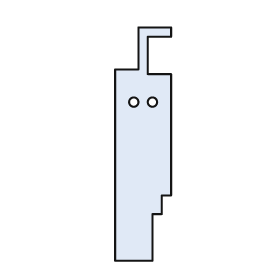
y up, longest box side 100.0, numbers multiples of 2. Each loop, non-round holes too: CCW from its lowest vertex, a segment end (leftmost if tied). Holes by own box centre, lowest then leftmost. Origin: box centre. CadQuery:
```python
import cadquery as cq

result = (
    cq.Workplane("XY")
    .moveTo(-12.0, -50.0)
    .lineTo(4.0, -50.0)
    .lineTo(4.0, -30.0)
    .lineTo(8.0, -30.0)
    .lineTo(8.0, -22.0)
    .lineTo(12.0, -22.0)
    .lineTo(12.0, 30.0)
    .lineTo(2.0, 30.0)
    .lineTo(2.0, 46.0)
    .lineTo(12.0, 46.0)
    .lineTo(12.0, 50.0)
    .lineTo(-2.0, 50.0)
    .lineTo(-2.0, 32.0)
    .lineTo(-12.0, 32.0)
    .close()
    .moveTo(-4.0, 18.0)
    .circle(2.0)
    .moveTo(4.0, 18.0)
    .circle(2.0)
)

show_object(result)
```